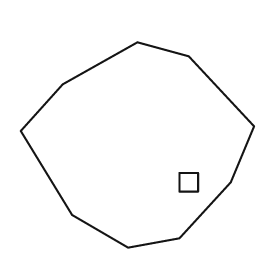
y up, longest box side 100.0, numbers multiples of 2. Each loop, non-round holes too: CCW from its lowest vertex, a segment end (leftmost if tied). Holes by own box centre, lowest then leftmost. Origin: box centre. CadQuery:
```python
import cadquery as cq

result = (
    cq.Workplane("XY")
    .moveTo(-4.0, -44.0)
    .lineTo(18.0, -40.0)
    .lineTo(40.0, -16.0)
    .lineTo(50.0, 8.0)
    .lineTo(22.0, 38.0)
    .lineTo(0.0, 44.0)
    .lineTo(-32.0, 26.0)
    .lineTo(-50.0, 6.0)
    .lineTo(-28.0, -30.0)
    .close()
    .moveTo(18.0, -20.0)
    .lineTo(26.0, -20.0)
    .lineTo(26.0, -12.0)
    .lineTo(18.0, -12.0)
    .close()
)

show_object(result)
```